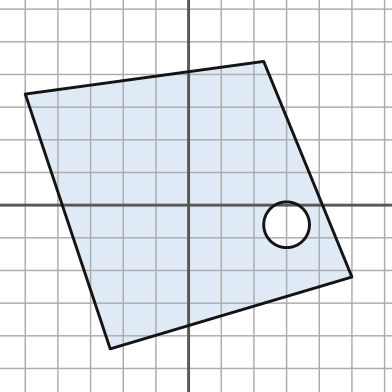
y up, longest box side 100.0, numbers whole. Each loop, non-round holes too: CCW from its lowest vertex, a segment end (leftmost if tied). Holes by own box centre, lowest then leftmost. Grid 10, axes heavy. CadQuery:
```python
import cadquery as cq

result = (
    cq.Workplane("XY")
    .moveTo(-24.0, -44.0)
    .lineTo(50.0, -22.0)
    .lineTo(23.0, 44.0)
    .lineTo(-50.0, 34.0)
    .close()
    .moveTo(30.0, -6.0)
    .circle(7.0)
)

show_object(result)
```